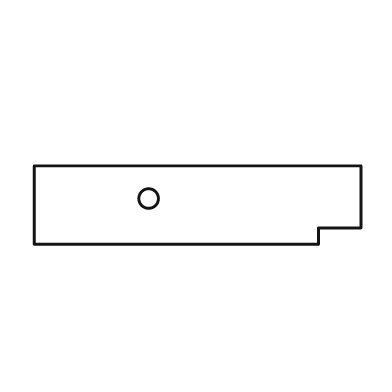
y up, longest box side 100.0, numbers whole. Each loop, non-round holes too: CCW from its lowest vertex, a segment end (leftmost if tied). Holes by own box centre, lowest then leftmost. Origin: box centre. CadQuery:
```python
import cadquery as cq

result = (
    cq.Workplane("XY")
    .moveTo(-50.0, -12.0)
    .lineTo(37.0, -12.0)
    .lineTo(37.0, -7.0)
    .lineTo(50.0, -7.0)
    .lineTo(50.0, 12.0)
    .lineTo(-50.0, 12.0)
    .close()
    .moveTo(-15.0, 2.0)
    .circle(3.0)
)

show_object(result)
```